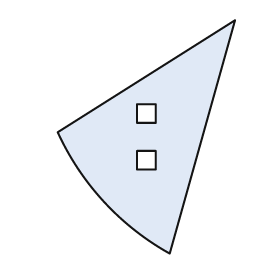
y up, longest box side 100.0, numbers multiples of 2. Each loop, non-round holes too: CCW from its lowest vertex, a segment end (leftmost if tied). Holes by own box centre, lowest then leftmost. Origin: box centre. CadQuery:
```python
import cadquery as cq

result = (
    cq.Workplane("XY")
    .moveTo(10.0, -50.0)
    .lineTo(38.0, 50.0)
    .lineTo(-38.0, 2.0)
    .threePointArc((-18.0, -28.0), (10.0, -50.0))
    .close()
    .moveTo(-4.0, -14.0)
    .lineTo(4.0, -14.0)
    .lineTo(4.0, -6.0)
    .lineTo(-4.0, -6.0)
    .close()
    .moveTo(-4.0, 6.0)
    .lineTo(4.0, 6.0)
    .lineTo(4.0, 14.0)
    .lineTo(-4.0, 14.0)
    .close()
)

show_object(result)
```